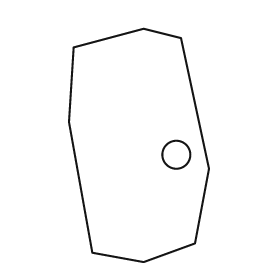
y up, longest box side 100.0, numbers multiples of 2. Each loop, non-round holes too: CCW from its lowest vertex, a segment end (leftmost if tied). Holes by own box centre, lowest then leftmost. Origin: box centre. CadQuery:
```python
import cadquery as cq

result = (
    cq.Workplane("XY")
    .moveTo(2.0, -50.0)
    .lineTo(24.0, -42.0)
    .lineTo(30.0, -10.0)
    .lineTo(18.0, 46.0)
    .lineTo(2.0, 50.0)
    .lineTo(-28.0, 42.0)
    .lineTo(-30.0, 10.0)
    .lineTo(-20.0, -46.0)
    .close()
    .moveTo(16.0, -4.0)
    .circle(6.0)
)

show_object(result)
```